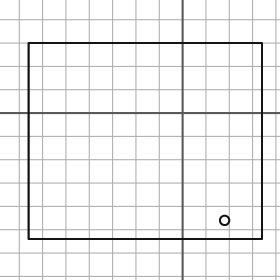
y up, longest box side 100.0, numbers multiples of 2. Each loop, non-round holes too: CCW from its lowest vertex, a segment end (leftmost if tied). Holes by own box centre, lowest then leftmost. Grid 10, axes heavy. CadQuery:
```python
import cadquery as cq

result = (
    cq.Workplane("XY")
    .moveTo(-66.0, -54.0)
    .lineTo(34.0, -54.0)
    .lineTo(34.0, 30.0)
    .lineTo(-66.0, 30.0)
    .close()
    .moveTo(18.0, -46.0)
    .circle(2.0)
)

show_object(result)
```